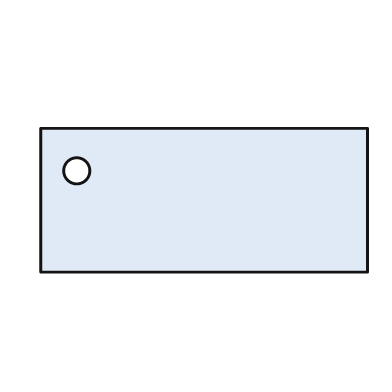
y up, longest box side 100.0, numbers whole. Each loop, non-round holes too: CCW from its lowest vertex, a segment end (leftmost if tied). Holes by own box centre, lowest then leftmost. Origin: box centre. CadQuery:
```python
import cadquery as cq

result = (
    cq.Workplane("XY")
    .moveTo(-50.0, -22.0)
    .lineTo(50.0, -22.0)
    .lineTo(50.0, 22.0)
    .lineTo(-50.0, 22.0)
    .close()
    .moveTo(-39.0, 9.0)
    .circle(4.0)
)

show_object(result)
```